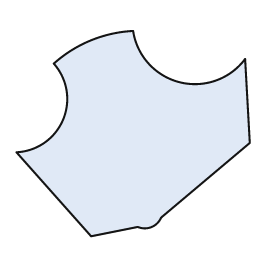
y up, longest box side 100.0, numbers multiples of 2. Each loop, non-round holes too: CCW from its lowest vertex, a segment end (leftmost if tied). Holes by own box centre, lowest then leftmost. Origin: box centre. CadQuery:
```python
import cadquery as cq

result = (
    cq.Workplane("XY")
    .moveTo(-18.0, -44.0)
    .lineTo(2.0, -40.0)
    .threePointArc((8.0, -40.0), (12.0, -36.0))
    .lineTo(50.0, -4.0)
    .lineTo(48.0, 32.0)
    .threePointArc((20.0, 22.0), (0.0, 44.0))
    .threePointArc((-18.0, 40.0), (-34.0, 30.0))
    .threePointArc((-30.0, 6.0), (-50.0, -8.0))
    .close()
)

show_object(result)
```